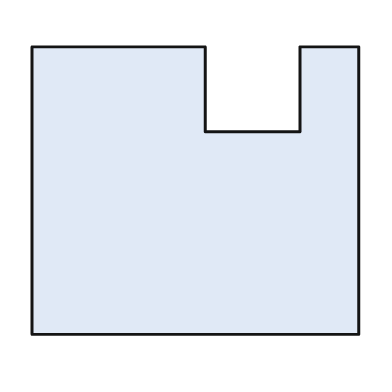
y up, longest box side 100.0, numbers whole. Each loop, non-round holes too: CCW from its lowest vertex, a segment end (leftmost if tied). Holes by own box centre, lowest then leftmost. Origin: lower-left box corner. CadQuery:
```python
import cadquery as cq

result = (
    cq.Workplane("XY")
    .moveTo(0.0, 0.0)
    .lineTo(100.0, 0.0)
    .lineTo(100.0, 88.0)
    .lineTo(82.0, 88.0)
    .lineTo(82.0, 62.0)
    .lineTo(53.0, 62.0)
    .lineTo(53.0, 88.0)
    .lineTo(0.0, 88.0)
    .close()
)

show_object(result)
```